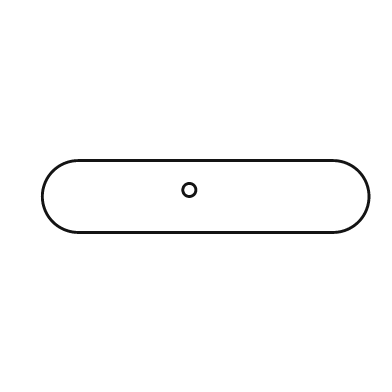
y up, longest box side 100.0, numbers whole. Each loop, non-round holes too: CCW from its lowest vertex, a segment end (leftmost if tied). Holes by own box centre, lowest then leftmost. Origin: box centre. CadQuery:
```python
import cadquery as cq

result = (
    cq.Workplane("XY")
    .moveTo(-39.0, -11.0)
    .lineTo(39.0, -11.0)
    .threePointArc((50.0, 0.0), (39.0, 11.0))
    .lineTo(-39.0, 11.0)
    .threePointArc((-50.0, 0.0), (-39.0, -11.0))
    .close()
    .moveTo(-5.0, 2.0)
    .circle(2.0)
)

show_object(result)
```